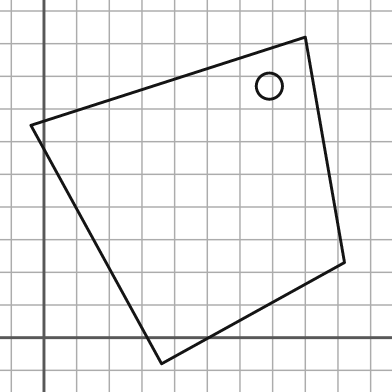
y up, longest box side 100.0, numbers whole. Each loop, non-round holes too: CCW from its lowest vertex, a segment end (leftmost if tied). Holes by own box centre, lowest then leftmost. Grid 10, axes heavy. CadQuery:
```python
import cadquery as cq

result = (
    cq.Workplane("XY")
    .moveTo(36.0, -8.0)
    .lineTo(92.0, 23.0)
    .lineTo(80.0, 92.0)
    .lineTo(-4.0, 65.0)
    .close()
    .moveTo(69.0, 77.0)
    .circle(4.0)
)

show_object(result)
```